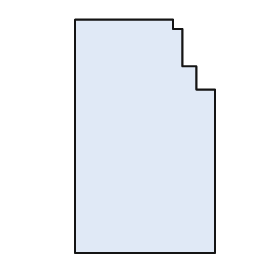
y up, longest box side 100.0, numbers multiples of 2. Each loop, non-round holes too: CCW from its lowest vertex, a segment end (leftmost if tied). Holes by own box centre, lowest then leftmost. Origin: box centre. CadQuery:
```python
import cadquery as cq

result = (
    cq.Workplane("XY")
    .moveTo(-30.0, -50.0)
    .lineTo(30.0, -50.0)
    .lineTo(30.0, 20.0)
    .lineTo(22.0, 20.0)
    .lineTo(22.0, 30.0)
    .lineTo(16.0, 30.0)
    .lineTo(16.0, 46.0)
    .lineTo(12.0, 46.0)
    .lineTo(12.0, 50.0)
    .lineTo(-30.0, 50.0)
    .close()
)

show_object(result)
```